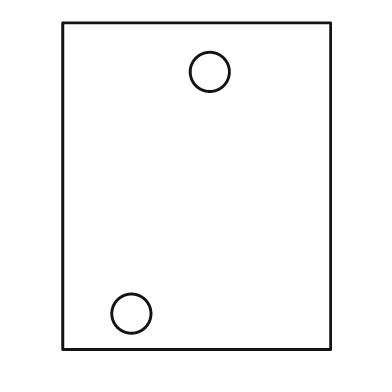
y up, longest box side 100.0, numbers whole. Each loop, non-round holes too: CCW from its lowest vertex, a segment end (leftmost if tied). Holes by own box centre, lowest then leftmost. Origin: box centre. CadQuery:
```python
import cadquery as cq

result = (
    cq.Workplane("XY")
    .moveTo(-41.0, -50.0)
    .lineTo(41.0, -50.0)
    .lineTo(41.0, 50.0)
    .lineTo(-41.0, 50.0)
    .close()
    .moveTo(-20.0, -39.0)
    .circle(6.0)
    .moveTo(4.0, 35.0)
    .circle(6.0)
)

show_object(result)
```